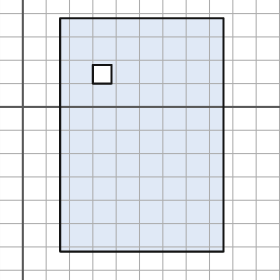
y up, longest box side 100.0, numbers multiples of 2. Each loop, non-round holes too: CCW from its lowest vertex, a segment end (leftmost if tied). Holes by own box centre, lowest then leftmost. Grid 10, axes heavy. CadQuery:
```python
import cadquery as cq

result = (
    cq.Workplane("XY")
    .moveTo(16.0, -62.0)
    .lineTo(86.0, -62.0)
    .lineTo(86.0, 38.0)
    .lineTo(16.0, 38.0)
    .close()
    .moveTo(30.0, 10.0)
    .lineTo(38.0, 10.0)
    .lineTo(38.0, 18.0)
    .lineTo(30.0, 18.0)
    .close()
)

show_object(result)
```